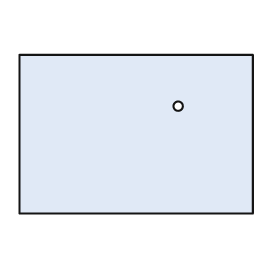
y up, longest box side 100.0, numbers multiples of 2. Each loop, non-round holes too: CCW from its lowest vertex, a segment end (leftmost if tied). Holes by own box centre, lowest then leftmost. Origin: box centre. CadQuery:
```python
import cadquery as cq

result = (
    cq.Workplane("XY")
    .moveTo(-50.0, -34.0)
    .lineTo(50.0, -34.0)
    .lineTo(50.0, 34.0)
    .lineTo(-50.0, 34.0)
    .close()
    .moveTo(18.0, 12.0)
    .circle(2.0)
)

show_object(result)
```